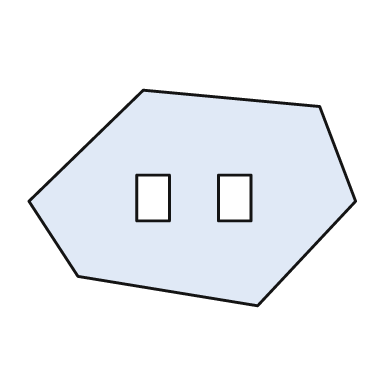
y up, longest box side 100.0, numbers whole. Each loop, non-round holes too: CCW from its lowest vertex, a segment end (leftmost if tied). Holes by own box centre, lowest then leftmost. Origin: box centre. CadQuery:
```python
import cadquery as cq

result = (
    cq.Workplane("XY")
    .moveTo(20.0, -33.0)
    .lineTo(50.0, -1.0)
    .lineTo(39.0, 28.0)
    .lineTo(-15.0, 33.0)
    .lineTo(-50.0, -1.0)
    .lineTo(-35.0, -24.0)
    .close()
    .moveTo(-17.0, -7.0)
    .lineTo(-7.0, -7.0)
    .lineTo(-7.0, 7.0)
    .lineTo(-17.0, 7.0)
    .close()
    .moveTo(8.0, -7.0)
    .lineTo(18.0, -7.0)
    .lineTo(18.0, 7.0)
    .lineTo(8.0, 7.0)
    .close()
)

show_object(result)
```